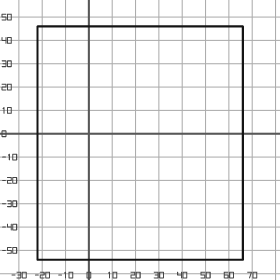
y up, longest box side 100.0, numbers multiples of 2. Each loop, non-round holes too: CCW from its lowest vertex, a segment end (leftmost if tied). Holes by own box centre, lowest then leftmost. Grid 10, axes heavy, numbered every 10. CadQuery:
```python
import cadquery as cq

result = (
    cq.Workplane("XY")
    .moveTo(-22.0, -54.0)
    .lineTo(66.0, -54.0)
    .lineTo(66.0, 46.0)
    .lineTo(-22.0, 46.0)
    .close()
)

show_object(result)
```